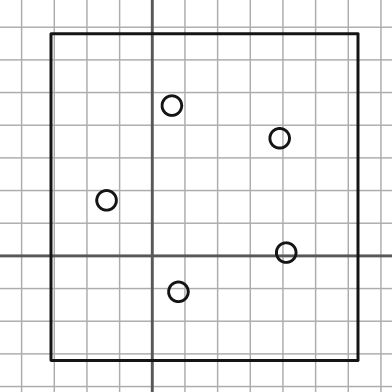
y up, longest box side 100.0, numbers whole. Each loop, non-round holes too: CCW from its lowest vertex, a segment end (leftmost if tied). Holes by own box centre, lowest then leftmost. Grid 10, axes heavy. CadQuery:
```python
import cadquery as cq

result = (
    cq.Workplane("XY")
    .moveTo(-31.0, -32.0)
    .lineTo(63.0, -32.0)
    .lineTo(63.0, 68.0)
    .lineTo(-31.0, 68.0)
    .close()
    .moveTo(8.0, -11.0)
    .circle(3.0)
    .moveTo(41.0, 1.0)
    .circle(3.0)
    .moveTo(-14.0, 17.0)
    .circle(3.0)
    .moveTo(39.0, 36.0)
    .circle(3.0)
    .moveTo(6.0, 46.0)
    .circle(3.0)
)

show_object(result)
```